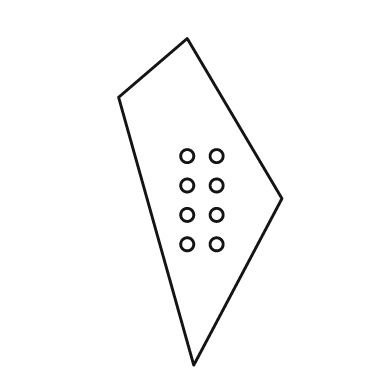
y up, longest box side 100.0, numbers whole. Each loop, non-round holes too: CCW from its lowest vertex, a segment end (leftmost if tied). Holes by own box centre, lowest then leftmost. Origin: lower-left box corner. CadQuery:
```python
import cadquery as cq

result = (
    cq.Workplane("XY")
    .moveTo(23.0, 0.0)
    .lineTo(50.0, 51.0)
    .lineTo(21.0, 100.0)
    .lineTo(0.0, 82.0)
    .close()
    .moveTo(21.0, 37.0)
    .circle(2.0)
    .moveTo(30.0, 37.0)
    .circle(2.0)
    .moveTo(21.0, 46.0)
    .circle(2.0)
    .moveTo(30.0, 46.0)
    .circle(2.0)
    .moveTo(21.0, 55.0)
    .circle(2.0)
    .moveTo(30.0, 55.0)
    .circle(2.0)
    .moveTo(21.0, 64.0)
    .circle(2.0)
    .moveTo(30.0, 64.0)
    .circle(2.0)
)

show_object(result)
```